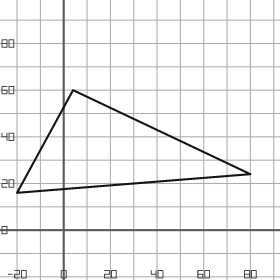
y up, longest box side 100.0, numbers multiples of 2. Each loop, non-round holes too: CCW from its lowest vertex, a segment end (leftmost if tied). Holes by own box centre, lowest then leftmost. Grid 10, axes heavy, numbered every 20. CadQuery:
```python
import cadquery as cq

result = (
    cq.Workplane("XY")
    .moveTo(-20.0, 16.0)
    .lineTo(80.0, 24.0)
    .lineTo(4.0, 60.0)
    .close()
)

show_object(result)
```